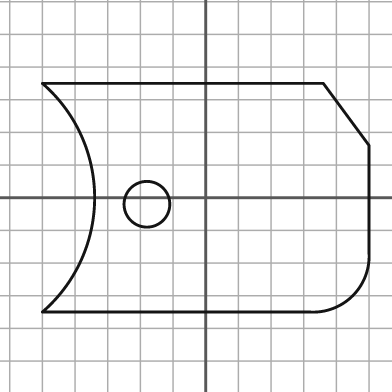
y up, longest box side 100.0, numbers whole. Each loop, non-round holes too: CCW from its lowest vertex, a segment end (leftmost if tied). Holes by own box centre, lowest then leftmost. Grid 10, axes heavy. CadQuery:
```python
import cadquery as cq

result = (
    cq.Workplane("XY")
    .moveTo(-50.0, -35.0)
    .lineTo(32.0, -35.0)
    .threePointArc((45.0, -30.0), (50.0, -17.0))
    .lineTo(50.0, 16.0)
    .lineTo(36.0, 35.0)
    .lineTo(-50.0, 35.0)
    .threePointArc((-34.0, 0.0), (-50.0, -35.0))
    .close()
    .moveTo(-18.0, -2.0)
    .circle(7.0)
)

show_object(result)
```